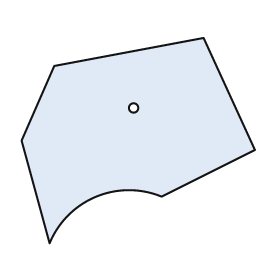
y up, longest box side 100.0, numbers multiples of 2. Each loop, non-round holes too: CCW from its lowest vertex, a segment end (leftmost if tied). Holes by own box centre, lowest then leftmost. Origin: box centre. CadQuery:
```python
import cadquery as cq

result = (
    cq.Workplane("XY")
    .moveTo(-38.0, -44.0)
    .threePointArc((-18.0, -24.0), (10.0, -24.0))
    .lineTo(50.0, -4.0)
    .lineTo(28.0, 44.0)
    .lineTo(-36.0, 32.0)
    .lineTo(-50.0, 0.0)
    .close()
    .moveTo(-2.0, 14.0)
    .circle(2.0)
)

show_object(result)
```